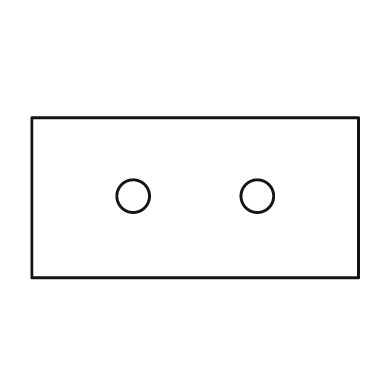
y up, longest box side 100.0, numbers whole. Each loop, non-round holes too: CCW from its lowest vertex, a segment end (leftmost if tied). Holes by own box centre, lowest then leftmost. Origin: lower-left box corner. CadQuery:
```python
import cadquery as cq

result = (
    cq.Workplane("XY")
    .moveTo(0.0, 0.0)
    .lineTo(100.0, 0.0)
    .lineTo(100.0, 49.0)
    .lineTo(0.0, 49.0)
    .close()
    .moveTo(31.0, 25.0)
    .circle(5.0)
    .moveTo(69.0, 25.0)
    .circle(5.0)
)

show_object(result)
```